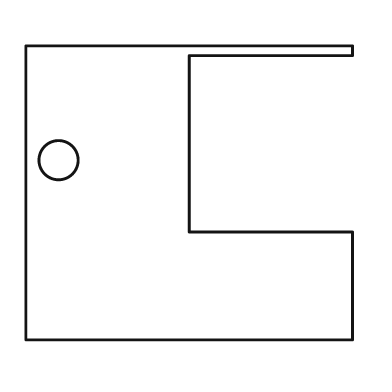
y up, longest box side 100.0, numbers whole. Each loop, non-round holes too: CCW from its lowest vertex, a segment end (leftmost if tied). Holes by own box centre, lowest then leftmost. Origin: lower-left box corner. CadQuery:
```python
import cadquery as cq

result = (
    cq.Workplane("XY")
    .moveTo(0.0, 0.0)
    .lineTo(100.0, 0.0)
    .lineTo(100.0, 33.0)
    .lineTo(50.0, 33.0)
    .lineTo(50.0, 87.0)
    .lineTo(100.0, 87.0)
    .lineTo(100.0, 90.0)
    .lineTo(0.0, 90.0)
    .close()
    .moveTo(10.0, 55.0)
    .circle(6.0)
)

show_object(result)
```